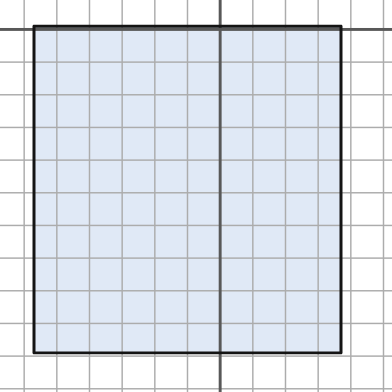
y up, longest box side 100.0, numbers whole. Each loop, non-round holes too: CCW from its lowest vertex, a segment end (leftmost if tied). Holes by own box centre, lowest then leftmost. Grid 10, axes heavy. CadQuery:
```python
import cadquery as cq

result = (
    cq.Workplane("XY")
    .moveTo(-57.0, -99.0)
    .lineTo(37.0, -99.0)
    .lineTo(37.0, 1.0)
    .lineTo(-57.0, 1.0)
    .close()
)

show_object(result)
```